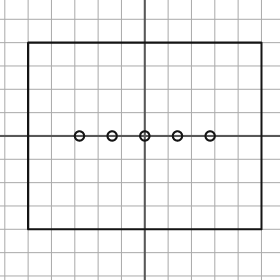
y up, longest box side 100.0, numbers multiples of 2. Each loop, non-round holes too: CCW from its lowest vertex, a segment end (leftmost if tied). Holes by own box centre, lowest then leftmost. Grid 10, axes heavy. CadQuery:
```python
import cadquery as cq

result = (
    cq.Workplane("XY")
    .moveTo(-50.0, -40.0)
    .lineTo(50.0, -40.0)
    .lineTo(50.0, 40.0)
    .lineTo(-50.0, 40.0)
    .close()
    .moveTo(-28.0, 0.0)
    .circle(2.0)
    .moveTo(-14.0, 0.0)
    .circle(2.0)
    .moveTo(0.0, 0.0)
    .circle(2.0)
    .moveTo(14.0, 0.0)
    .circle(2.0)
    .moveTo(28.0, 0.0)
    .circle(2.0)
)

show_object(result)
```